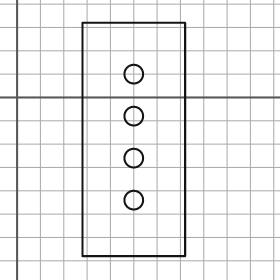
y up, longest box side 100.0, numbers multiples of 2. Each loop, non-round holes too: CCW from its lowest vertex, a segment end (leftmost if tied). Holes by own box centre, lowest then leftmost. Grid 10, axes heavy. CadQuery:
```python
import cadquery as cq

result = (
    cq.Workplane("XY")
    .moveTo(28.0, -68.0)
    .lineTo(72.0, -68.0)
    .lineTo(72.0, 32.0)
    .lineTo(28.0, 32.0)
    .close()
    .moveTo(50.0, -44.0)
    .circle(4.0)
    .moveTo(50.0, -26.0)
    .circle(4.0)
    .moveTo(50.0, -8.0)
    .circle(4.0)
    .moveTo(50.0, 10.0)
    .circle(4.0)
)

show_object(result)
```